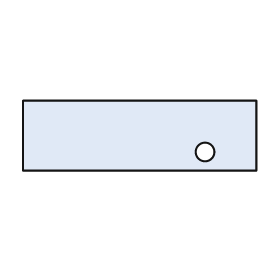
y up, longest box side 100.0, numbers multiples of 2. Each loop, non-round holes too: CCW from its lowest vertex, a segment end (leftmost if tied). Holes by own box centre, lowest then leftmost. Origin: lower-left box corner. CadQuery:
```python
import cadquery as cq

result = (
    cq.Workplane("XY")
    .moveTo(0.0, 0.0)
    .lineTo(100.0, 0.0)
    .lineTo(100.0, 30.0)
    .lineTo(0.0, 30.0)
    .close()
    .moveTo(78.0, 8.0)
    .circle(4.0)
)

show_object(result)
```